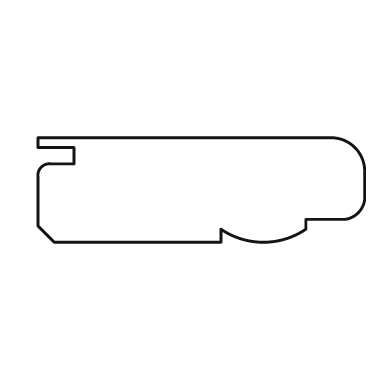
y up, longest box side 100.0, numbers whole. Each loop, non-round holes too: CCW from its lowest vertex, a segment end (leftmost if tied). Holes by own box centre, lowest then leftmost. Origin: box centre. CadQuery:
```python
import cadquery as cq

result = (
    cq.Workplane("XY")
    .moveTo(-45.0, -16.0)
    .lineTo(6.0, -16.0)
    .lineTo(6.0, -12.0)
    .threePointArc((19.0, -16.0), (32.0, -12.0))
    .lineTo(32.0, -9.0)
    .lineTo(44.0, -9.0)
    .threePointArc((48.0, -7.0), (50.0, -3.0))
    .lineTo(50.0, 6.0)
    .threePointArc((47.0, 13.0), (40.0, 16.0))
    .lineTo(-50.0, 16.0)
    .lineTo(-50.0, 13.0)
    .lineTo(-39.0, 13.0)
    .lineTo(-39.0, 8.0)
    .lineTo(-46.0, 8.0)
    .threePointArc((-49.0, 7.0), (-50.0, 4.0))
    .lineTo(-50.0, -11.0)
    .close()
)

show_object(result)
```